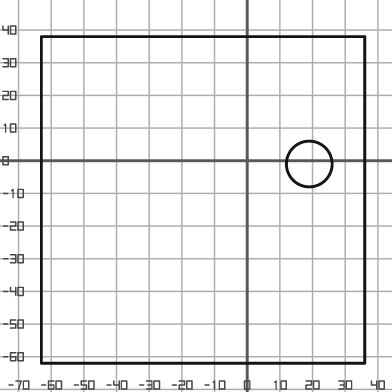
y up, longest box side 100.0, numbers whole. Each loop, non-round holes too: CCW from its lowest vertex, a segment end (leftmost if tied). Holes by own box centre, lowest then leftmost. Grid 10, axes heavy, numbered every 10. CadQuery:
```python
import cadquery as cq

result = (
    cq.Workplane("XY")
    .moveTo(-63.0, -62.0)
    .lineTo(36.0, -62.0)
    .lineTo(36.0, 38.0)
    .lineTo(-63.0, 38.0)
    .close()
    .moveTo(19.0, -1.0)
    .circle(7.0)
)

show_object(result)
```